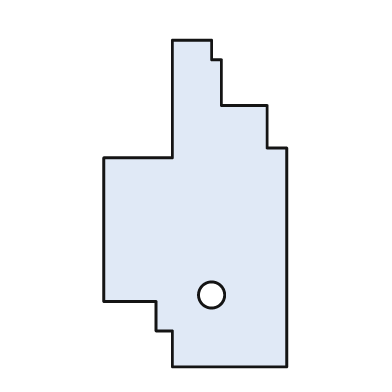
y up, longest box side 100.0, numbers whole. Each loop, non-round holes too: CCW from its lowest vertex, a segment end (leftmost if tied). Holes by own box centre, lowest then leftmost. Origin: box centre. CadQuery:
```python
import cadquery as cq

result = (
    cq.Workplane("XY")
    .moveTo(-7.0, -50.0)
    .lineTo(28.0, -50.0)
    .lineTo(28.0, 17.0)
    .lineTo(22.0, 17.0)
    .lineTo(22.0, 30.0)
    .lineTo(8.0, 30.0)
    .lineTo(8.0, 44.0)
    .lineTo(5.0, 44.0)
    .lineTo(5.0, 50.0)
    .lineTo(-7.0, 50.0)
    .lineTo(-7.0, 14.0)
    .lineTo(-28.0, 14.0)
    .lineTo(-28.0, -30.0)
    .lineTo(-12.0, -30.0)
    .lineTo(-12.0, -39.0)
    .lineTo(-7.0, -39.0)
    .close()
    .moveTo(5.0, -28.0)
    .circle(4.0)
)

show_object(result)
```